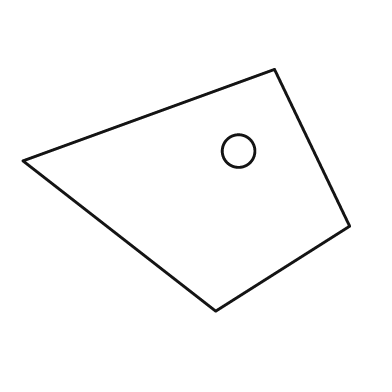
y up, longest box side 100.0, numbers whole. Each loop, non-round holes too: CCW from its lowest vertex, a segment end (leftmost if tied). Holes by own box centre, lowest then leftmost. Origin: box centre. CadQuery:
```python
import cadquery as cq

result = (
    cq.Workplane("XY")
    .moveTo(9.0, -37.0)
    .lineTo(50.0, -11.0)
    .lineTo(27.0, 37.0)
    .lineTo(-50.0, 9.0)
    .close()
    .moveTo(16.0, 12.0)
    .circle(5.0)
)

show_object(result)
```